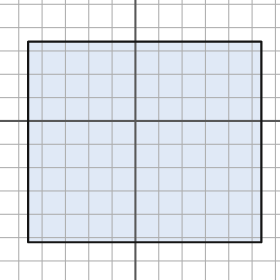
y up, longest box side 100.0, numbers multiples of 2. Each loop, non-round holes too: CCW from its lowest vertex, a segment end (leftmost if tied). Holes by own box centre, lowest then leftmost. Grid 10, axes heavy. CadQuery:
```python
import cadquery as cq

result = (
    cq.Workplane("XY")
    .moveTo(-46.0, -52.0)
    .lineTo(54.0, -52.0)
    .lineTo(54.0, 34.0)
    .lineTo(-46.0, 34.0)
    .close()
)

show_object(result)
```